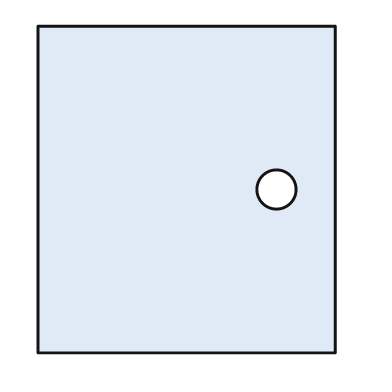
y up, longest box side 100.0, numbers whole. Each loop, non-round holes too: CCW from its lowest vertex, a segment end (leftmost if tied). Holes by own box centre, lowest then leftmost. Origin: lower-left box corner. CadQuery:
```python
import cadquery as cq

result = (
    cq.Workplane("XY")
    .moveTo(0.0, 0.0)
    .lineTo(91.0, 0.0)
    .lineTo(91.0, 100.0)
    .lineTo(0.0, 100.0)
    .close()
    .moveTo(73.0, 50.0)
    .circle(6.0)
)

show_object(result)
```